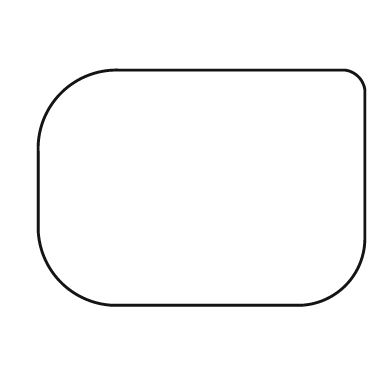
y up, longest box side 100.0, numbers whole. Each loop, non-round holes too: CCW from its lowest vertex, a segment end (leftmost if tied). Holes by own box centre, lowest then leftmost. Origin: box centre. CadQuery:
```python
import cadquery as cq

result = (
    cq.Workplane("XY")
    .moveTo(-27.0, -36.0)
    .lineTo(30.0, -36.0)
    .threePointArc((44.0, -30.0), (50.0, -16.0))
    .lineTo(50.0, 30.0)
    .threePointArc((48.0, 34.0), (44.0, 36.0))
    .lineTo(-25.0, 36.0)
    .threePointArc((-43.0, 29.0), (-50.0, 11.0))
    .lineTo(-50.0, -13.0)
    .threePointArc((-43.0, -29.0), (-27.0, -36.0))
    .close()
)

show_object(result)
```